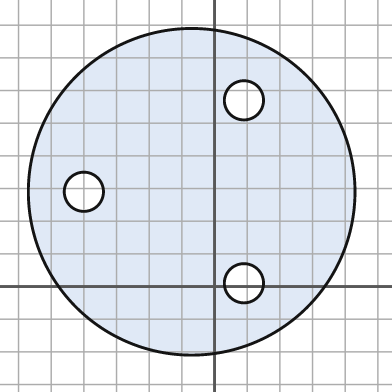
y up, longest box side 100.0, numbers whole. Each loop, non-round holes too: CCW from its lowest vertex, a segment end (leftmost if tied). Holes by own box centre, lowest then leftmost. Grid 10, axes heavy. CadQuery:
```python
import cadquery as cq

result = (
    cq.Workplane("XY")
    .moveTo(-7.0, 29.0)
    .circle(50.0)
    .moveTo(9.0, 1.0)
    .circle(6.0)
    .moveTo(-40.0, 29.0)
    .circle(6.0)
    .moveTo(9.0, 57.0)
    .circle(6.0)
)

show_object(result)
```